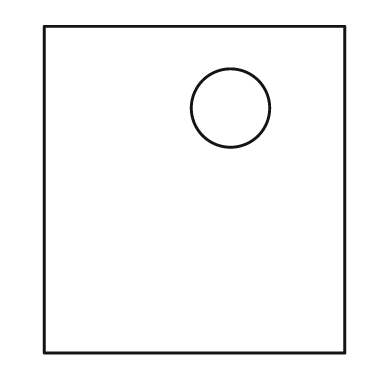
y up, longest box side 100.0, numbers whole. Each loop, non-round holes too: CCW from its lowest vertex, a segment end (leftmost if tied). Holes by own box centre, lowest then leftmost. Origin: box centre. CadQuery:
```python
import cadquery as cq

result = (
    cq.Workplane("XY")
    .moveTo(-46.0, -50.0)
    .lineTo(46.0, -50.0)
    .lineTo(46.0, 50.0)
    .lineTo(-46.0, 50.0)
    .close()
    .moveTo(11.0, 25.0)
    .circle(12.0)
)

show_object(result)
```